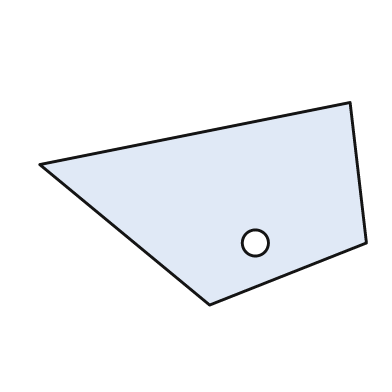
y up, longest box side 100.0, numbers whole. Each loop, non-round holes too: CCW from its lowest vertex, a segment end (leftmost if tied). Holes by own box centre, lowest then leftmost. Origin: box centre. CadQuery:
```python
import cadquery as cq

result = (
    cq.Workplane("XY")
    .moveTo(2.0, -31.0)
    .lineTo(50.0, -12.0)
    .lineTo(45.0, 31.0)
    .lineTo(-50.0, 12.0)
    .close()
    .moveTo(16.0, -12.0)
    .circle(4.0)
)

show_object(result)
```